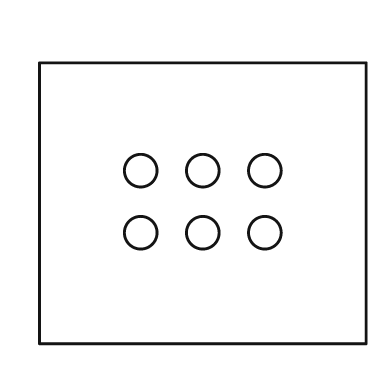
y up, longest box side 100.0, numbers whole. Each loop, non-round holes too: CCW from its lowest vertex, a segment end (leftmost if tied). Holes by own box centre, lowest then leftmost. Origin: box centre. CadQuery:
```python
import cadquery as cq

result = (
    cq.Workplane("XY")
    .moveTo(-50.0, -43.0)
    .lineTo(50.0, -43.0)
    .lineTo(50.0, 43.0)
    .lineTo(-50.0, 43.0)
    .close()
    .moveTo(-19.0, -9.0)
    .circle(5.0)
    .moveTo(0.0, -9.0)
    .circle(5.0)
    .moveTo(19.0, -9.0)
    .circle(5.0)
    .moveTo(-19.0, 10.0)
    .circle(5.0)
    .moveTo(0.0, 10.0)
    .circle(5.0)
    .moveTo(19.0, 10.0)
    .circle(5.0)
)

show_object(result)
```